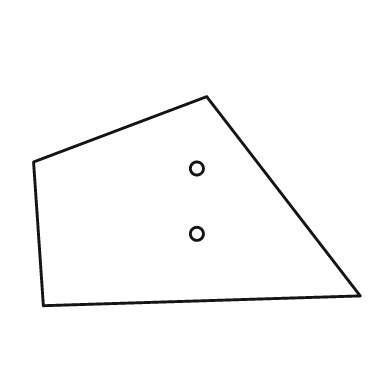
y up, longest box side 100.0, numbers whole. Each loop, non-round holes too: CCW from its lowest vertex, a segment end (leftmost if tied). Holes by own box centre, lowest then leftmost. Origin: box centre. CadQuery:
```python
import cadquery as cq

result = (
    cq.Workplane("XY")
    .moveTo(-47.0, -32.0)
    .lineTo(50.0, -29.0)
    .lineTo(3.0, 32.0)
    .lineTo(-50.0, 12.0)
    .close()
    .moveTo(0.0, -10.0)
    .circle(2.0)
    .moveTo(0.0, 10.0)
    .circle(2.0)
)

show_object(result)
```